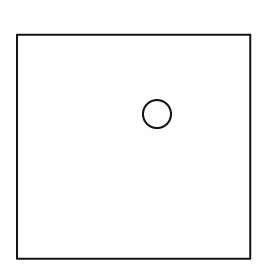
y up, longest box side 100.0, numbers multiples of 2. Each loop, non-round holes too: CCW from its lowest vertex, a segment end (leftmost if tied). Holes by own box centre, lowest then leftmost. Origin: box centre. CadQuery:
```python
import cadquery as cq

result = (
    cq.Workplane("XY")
    .moveTo(-50.0, -48.0)
    .lineTo(50.0, -48.0)
    .lineTo(50.0, 48.0)
    .lineTo(-50.0, 48.0)
    .close()
    .moveTo(10.0, 14.0)
    .circle(6.0)
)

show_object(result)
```